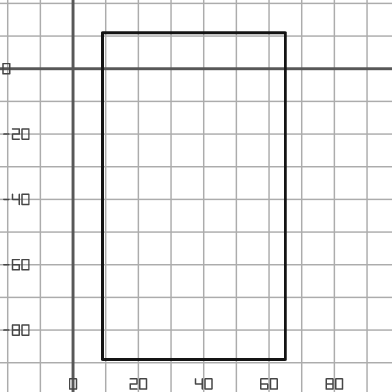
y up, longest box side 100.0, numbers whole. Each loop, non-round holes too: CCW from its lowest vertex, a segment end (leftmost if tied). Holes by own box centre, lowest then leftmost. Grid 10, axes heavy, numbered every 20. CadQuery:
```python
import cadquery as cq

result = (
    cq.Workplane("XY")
    .moveTo(9.0, -89.0)
    .lineTo(65.0, -89.0)
    .lineTo(65.0, 11.0)
    .lineTo(9.0, 11.0)
    .close()
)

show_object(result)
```